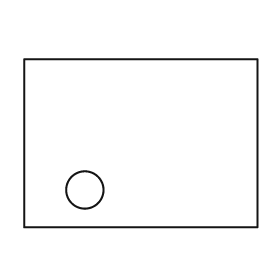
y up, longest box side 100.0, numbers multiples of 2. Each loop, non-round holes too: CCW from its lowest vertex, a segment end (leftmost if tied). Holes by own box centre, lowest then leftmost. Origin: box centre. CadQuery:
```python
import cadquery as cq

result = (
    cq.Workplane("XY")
    .moveTo(-50.0, -36.0)
    .lineTo(50.0, -36.0)
    .lineTo(50.0, 36.0)
    .lineTo(-50.0, 36.0)
    .close()
    .moveTo(-24.0, -20.0)
    .circle(8.0)
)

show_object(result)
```